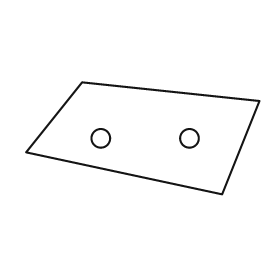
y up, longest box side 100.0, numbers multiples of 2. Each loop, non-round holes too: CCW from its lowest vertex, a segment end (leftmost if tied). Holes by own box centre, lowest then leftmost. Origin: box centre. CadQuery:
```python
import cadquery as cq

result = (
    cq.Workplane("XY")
    .moveTo(34.0, -24.0)
    .lineTo(50.0, 16.0)
    .lineTo(-26.0, 24.0)
    .lineTo(-50.0, -6.0)
    .close()
    .moveTo(-18.0, 0.0)
    .circle(4.0)
    .moveTo(20.0, 0.0)
    .circle(4.0)
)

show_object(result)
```